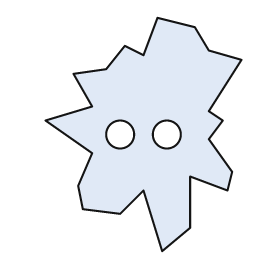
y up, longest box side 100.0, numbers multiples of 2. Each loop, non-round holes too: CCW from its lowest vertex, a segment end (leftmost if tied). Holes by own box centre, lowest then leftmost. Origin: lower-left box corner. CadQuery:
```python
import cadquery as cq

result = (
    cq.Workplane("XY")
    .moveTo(50.0, 0.0)
    .lineTo(62.0, 10.0)
    .lineTo(62.0, 32.0)
    .lineTo(78.0, 26.0)
    .lineTo(80.0, 34.0)
    .lineTo(70.0, 48.0)
    .lineTo(76.0, 56.0)
    .lineTo(70.0, 60.0)
    .lineTo(84.0, 82.0)
    .lineTo(70.0, 86.0)
    .lineTo(64.0, 96.0)
    .lineTo(48.0, 100.0)
    .lineTo(42.0, 84.0)
    .lineTo(34.0, 88.0)
    .lineTo(26.0, 78.0)
    .lineTo(12.0, 76.0)
    .lineTo(20.0, 62.0)
    .lineTo(0.0, 56.0)
    .lineTo(20.0, 42.0)
    .lineTo(14.0, 28.0)
    .lineTo(16.0, 18.0)
    .lineTo(32.0, 16.0)
    .lineTo(42.0, 26.0)
    .close()
    .moveTo(32.0, 50.0)
    .circle(6.0)
    .moveTo(52.0, 50.0)
    .circle(6.0)
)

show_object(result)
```